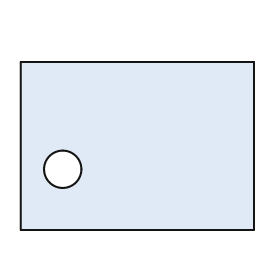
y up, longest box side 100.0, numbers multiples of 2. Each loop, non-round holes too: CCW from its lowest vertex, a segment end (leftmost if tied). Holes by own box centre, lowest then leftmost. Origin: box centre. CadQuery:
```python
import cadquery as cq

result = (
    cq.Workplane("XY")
    .moveTo(-50.0, -36.0)
    .lineTo(50.0, -36.0)
    .lineTo(50.0, 36.0)
    .lineTo(-50.0, 36.0)
    .close()
    .moveTo(-32.0, -10.0)
    .circle(8.0)
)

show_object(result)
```